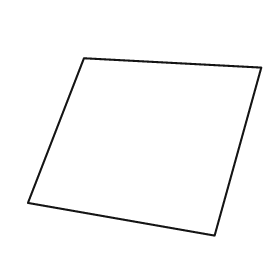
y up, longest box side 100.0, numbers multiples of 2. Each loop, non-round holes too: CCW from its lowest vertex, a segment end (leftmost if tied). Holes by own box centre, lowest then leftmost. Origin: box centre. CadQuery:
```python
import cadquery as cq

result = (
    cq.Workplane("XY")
    .moveTo(30.0, -38.0)
    .lineTo(50.0, 34.0)
    .lineTo(-26.0, 38.0)
    .lineTo(-50.0, -24.0)
    .close()
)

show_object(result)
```